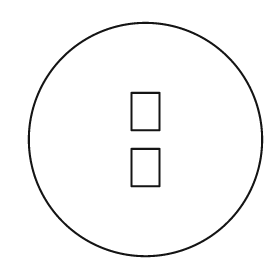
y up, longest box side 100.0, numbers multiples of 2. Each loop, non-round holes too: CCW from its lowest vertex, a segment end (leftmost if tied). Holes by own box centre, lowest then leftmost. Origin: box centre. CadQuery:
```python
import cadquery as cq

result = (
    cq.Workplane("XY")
    .moveTo(0.0, 0.0)
    .circle(50.0)
    .moveTo(-6.0, -20.0)
    .lineTo(6.0, -20.0)
    .lineTo(6.0, -4.0)
    .lineTo(-6.0, -4.0)
    .close()
    .moveTo(-6.0, 4.0)
    .lineTo(6.0, 4.0)
    .lineTo(6.0, 20.0)
    .lineTo(-6.0, 20.0)
    .close()
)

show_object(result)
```